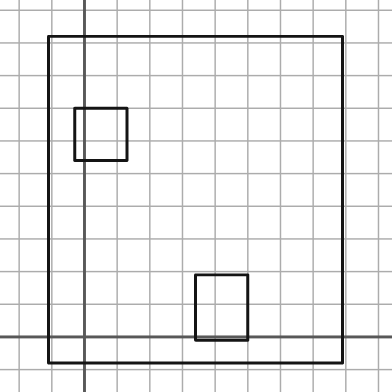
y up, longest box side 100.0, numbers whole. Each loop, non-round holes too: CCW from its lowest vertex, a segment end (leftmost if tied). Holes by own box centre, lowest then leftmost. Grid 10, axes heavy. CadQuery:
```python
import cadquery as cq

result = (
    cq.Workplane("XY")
    .moveTo(-11.0, -8.0)
    .lineTo(79.0, -8.0)
    .lineTo(79.0, 92.0)
    .lineTo(-11.0, 92.0)
    .close()
    .moveTo(34.0, -1.0)
    .lineTo(50.0, -1.0)
    .lineTo(50.0, 19.0)
    .lineTo(34.0, 19.0)
    .close()
    .moveTo(-3.0, 54.0)
    .lineTo(13.0, 54.0)
    .lineTo(13.0, 70.0)
    .lineTo(-3.0, 70.0)
    .close()
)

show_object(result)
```